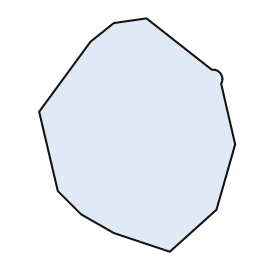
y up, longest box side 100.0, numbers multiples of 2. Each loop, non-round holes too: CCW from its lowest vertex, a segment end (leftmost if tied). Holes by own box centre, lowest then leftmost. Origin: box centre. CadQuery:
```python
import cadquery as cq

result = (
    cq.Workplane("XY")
    .moveTo(14.0, -50.0)
    .lineTo(34.0, -32.0)
    .lineTo(42.0, -4.0)
    .lineTo(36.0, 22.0)
    .threePointArc((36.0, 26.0), (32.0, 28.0))
    .lineTo(4.0, 50.0)
    .lineTo(-10.0, 48.0)
    .lineTo(-20.0, 40.0)
    .lineTo(-42.0, 10.0)
    .lineTo(-34.0, -24.0)
    .lineTo(-24.0, -34.0)
    .lineTo(-10.0, -42.0)
    .close()
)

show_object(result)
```